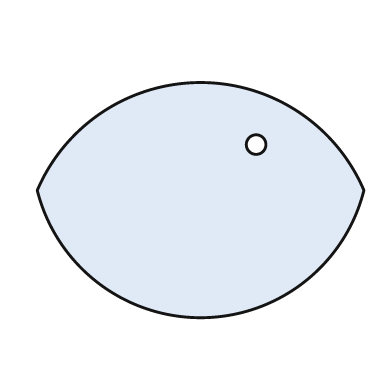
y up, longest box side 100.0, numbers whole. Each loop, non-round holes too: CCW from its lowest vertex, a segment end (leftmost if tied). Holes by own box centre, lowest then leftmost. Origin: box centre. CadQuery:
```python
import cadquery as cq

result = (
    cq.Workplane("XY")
    .moveTo(-50.0, 3.0)
    .threePointArc((0.0, -36.0), (50.0, 3.0))
    .threePointArc((0.0, 36.0), (-50.0, 3.0))
    .close()
    .moveTo(17.0, 17.0)
    .circle(3.0)
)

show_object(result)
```